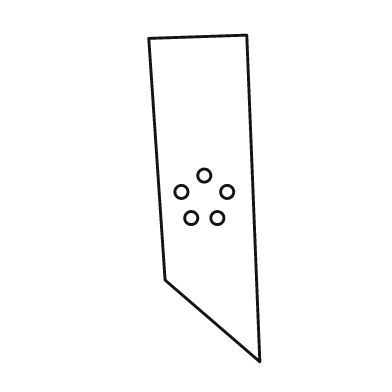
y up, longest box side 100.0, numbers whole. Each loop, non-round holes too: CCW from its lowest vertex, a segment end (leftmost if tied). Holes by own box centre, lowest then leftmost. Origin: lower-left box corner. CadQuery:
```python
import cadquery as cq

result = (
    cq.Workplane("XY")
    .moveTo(34.0, 0.0)
    .lineTo(30.0, 100.0)
    .lineTo(0.0, 99.0)
    .lineTo(5.0, 25.0)
    .close()
    .moveTo(13.0, 44.0)
    .circle(2.0)
    .moveTo(21.0, 44.0)
    .circle(2.0)
    .moveTo(10.0, 52.0)
    .circle(2.0)
    .moveTo(24.0, 52.0)
    .circle(2.0)
    .moveTo(17.0, 57.0)
    .circle(2.0)
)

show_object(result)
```